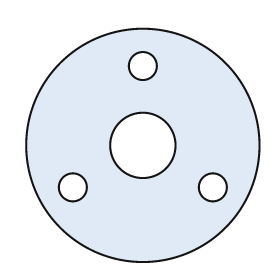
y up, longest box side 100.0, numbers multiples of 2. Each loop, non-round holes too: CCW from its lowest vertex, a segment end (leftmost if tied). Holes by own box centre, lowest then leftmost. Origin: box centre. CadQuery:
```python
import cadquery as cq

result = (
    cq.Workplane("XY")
    .moveTo(0.0, 0.0)
    .circle(50.0)
    .moveTo(-30.0, -18.0)
    .circle(6.0)
    .moveTo(30.0, -18.0)
    .circle(6.0)
    .moveTo(0.0, 0.0)
    .circle(14.0)
    .moveTo(0.0, 34.0)
    .circle(6.0)
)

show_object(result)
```